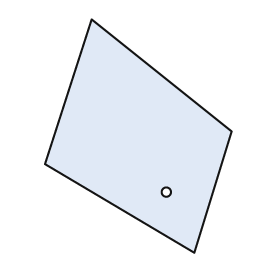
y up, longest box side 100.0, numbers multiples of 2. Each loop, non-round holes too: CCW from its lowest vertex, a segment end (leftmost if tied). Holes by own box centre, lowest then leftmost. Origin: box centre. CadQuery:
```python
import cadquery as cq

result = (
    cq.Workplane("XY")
    .moveTo(24.0, -50.0)
    .lineTo(40.0, 2.0)
    .lineTo(-20.0, 50.0)
    .lineTo(-40.0, -12.0)
    .close()
    .moveTo(12.0, -24.0)
    .circle(2.0)
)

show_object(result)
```